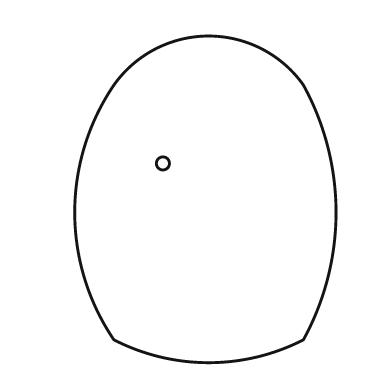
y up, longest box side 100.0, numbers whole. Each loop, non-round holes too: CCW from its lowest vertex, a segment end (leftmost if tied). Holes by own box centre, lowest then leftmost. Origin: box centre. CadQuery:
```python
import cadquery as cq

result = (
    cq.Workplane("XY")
    .moveTo(-28.0, -43.0)
    .threePointArc((1.0, -50.0), (30.0, -43.0))
    .threePointArc((40.0, -4.0), (30.0, 35.0))
    .threePointArc((1.0, 50.0), (-28.0, 35.0))
    .threePointArc((-40.0, -4.0), (-28.0, -43.0))
    .close()
    .moveTo(-13.0, 11.0)
    .circle(2.0)
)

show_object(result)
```